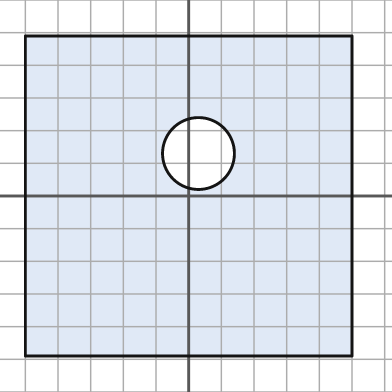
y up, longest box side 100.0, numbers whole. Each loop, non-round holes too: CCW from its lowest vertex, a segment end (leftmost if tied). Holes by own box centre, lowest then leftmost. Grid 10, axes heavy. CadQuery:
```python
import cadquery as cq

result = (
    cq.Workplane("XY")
    .moveTo(-50.0, -49.0)
    .lineTo(50.0, -49.0)
    .lineTo(50.0, 49.0)
    .lineTo(-50.0, 49.0)
    .close()
    .moveTo(3.0, 13.0)
    .circle(11.0)
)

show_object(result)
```